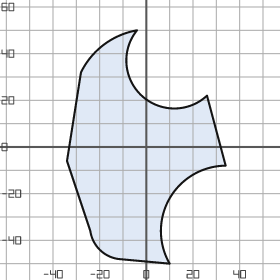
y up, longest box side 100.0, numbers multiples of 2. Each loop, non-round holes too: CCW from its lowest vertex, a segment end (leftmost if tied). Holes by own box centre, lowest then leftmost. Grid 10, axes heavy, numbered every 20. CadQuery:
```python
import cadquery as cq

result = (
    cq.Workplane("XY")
    .moveTo(10.0, -50.0)
    .threePointArc((10.0, -22.0), (34.0, -8.0))
    .lineTo(26.0, 22.0)
    .threePointArc((-2.0, 22.0), (-4.0, 50.0))
    .threePointArc((-18.0, 44.0), (-28.0, 32.0))
    .lineTo(-34.0, -6.0)
    .lineTo(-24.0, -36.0)
    .threePointArc((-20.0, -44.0), (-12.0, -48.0))
    .close()
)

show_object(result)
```